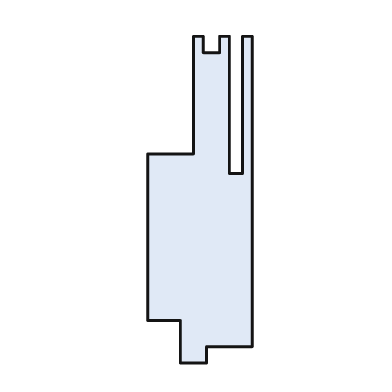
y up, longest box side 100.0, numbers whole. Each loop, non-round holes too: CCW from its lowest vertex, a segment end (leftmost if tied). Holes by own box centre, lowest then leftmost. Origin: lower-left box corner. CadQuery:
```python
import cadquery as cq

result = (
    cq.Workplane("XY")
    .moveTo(10.0, 0.0)
    .lineTo(18.0, 0.0)
    .lineTo(18.0, 5.0)
    .lineTo(32.0, 5.0)
    .lineTo(32.0, 100.0)
    .lineTo(29.0, 100.0)
    .lineTo(29.0, 58.0)
    .lineTo(25.0, 58.0)
    .lineTo(25.0, 100.0)
    .lineTo(22.0, 100.0)
    .lineTo(22.0, 95.0)
    .lineTo(17.0, 95.0)
    .lineTo(17.0, 100.0)
    .lineTo(14.0, 100.0)
    .lineTo(14.0, 64.0)
    .lineTo(0.0, 64.0)
    .lineTo(0.0, 13.0)
    .lineTo(10.0, 13.0)
    .close()
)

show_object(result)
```